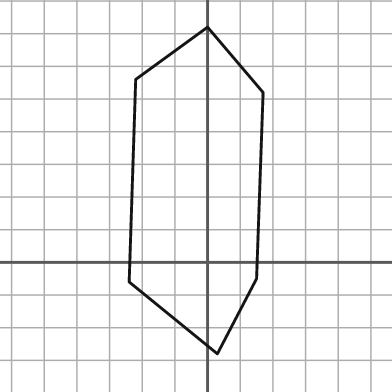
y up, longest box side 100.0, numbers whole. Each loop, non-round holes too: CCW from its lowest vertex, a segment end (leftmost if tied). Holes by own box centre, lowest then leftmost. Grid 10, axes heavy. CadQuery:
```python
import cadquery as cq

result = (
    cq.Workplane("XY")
    .moveTo(3.0, -28.0)
    .lineTo(15.0, -5.0)
    .lineTo(17.0, 52.0)
    .lineTo(0.0, 72.0)
    .lineTo(-22.0, 56.0)
    .lineTo(-24.0, -6.0)
    .close()
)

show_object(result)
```